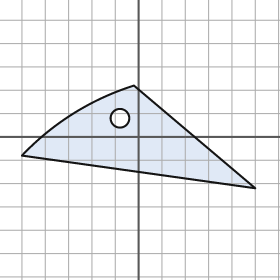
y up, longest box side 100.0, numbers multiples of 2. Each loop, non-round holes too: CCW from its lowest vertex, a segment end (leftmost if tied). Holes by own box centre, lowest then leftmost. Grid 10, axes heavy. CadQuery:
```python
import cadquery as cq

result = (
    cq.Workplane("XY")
    .moveTo(50.0, -22.0)
    .lineTo(-2.0, 22.0)
    .threePointArc((-28.0, 10.0), (-50.0, -8.0))
    .close()
    .moveTo(-8.0, 8.0)
    .circle(4.0)
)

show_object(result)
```